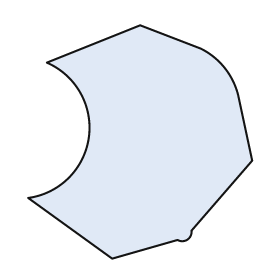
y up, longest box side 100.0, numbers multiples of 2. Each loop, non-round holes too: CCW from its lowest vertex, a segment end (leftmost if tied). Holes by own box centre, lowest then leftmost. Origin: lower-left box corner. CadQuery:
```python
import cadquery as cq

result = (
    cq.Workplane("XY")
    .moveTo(36.0, 0.0)
    .lineTo(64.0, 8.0)
    .threePointArc((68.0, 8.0), (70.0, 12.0))
    .lineTo(96.0, 42.0)
    .lineTo(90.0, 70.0)
    .threePointArc((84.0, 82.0), (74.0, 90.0))
    .lineTo(48.0, 100.0)
    .lineTo(8.0, 84.0)
    .threePointArc((26.0, 52.0), (0.0, 26.0))
    .close()
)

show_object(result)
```